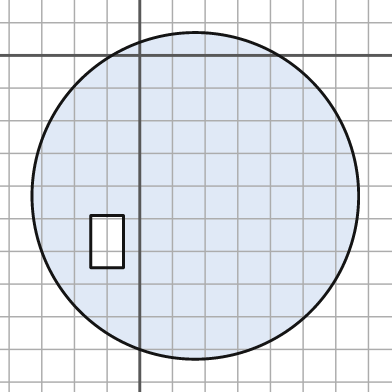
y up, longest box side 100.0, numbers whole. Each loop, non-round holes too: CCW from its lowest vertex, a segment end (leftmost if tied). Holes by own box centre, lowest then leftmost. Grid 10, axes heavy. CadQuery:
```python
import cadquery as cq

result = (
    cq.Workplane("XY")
    .moveTo(17.0, -43.0)
    .circle(50.0)
    .moveTo(-15.0, -65.0)
    .lineTo(-5.0, -65.0)
    .lineTo(-5.0, -49.0)
    .lineTo(-15.0, -49.0)
    .close()
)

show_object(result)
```